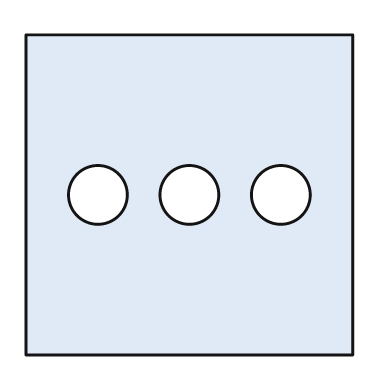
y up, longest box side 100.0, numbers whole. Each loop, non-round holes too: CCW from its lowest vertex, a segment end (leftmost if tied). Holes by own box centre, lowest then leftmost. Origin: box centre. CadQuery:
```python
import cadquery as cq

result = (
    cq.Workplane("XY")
    .moveTo(-50.0, -49.0)
    .lineTo(50.0, -49.0)
    .lineTo(50.0, 49.0)
    .lineTo(-50.0, 49.0)
    .close()
    .moveTo(-28.0, 0.0)
    .circle(9.0)
    .moveTo(0.0, 0.0)
    .circle(9.0)
    .moveTo(28.0, 0.0)
    .circle(9.0)
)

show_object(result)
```